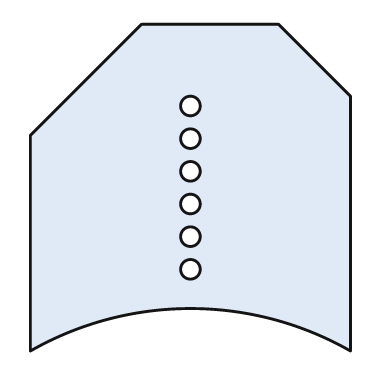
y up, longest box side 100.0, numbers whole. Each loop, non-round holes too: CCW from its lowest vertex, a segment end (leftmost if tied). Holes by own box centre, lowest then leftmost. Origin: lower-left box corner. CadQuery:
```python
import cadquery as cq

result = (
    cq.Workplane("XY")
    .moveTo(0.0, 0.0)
    .threePointArc((49.0, 13.0), (98.0, 0.0))
    .lineTo(98.0, 78.0)
    .lineTo(76.0, 100.0)
    .lineTo(34.0, 100.0)
    .lineTo(0.0, 66.0)
    .close()
    .moveTo(49.0, 25.0)
    .circle(3.0)
    .moveTo(49.0, 35.0)
    .circle(3.0)
    .moveTo(49.0, 45.0)
    .circle(3.0)
    .moveTo(49.0, 55.0)
    .circle(3.0)
    .moveTo(49.0, 65.0)
    .circle(3.0)
    .moveTo(49.0, 75.0)
    .circle(3.0)
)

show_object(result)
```